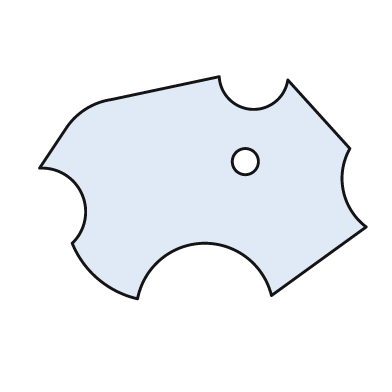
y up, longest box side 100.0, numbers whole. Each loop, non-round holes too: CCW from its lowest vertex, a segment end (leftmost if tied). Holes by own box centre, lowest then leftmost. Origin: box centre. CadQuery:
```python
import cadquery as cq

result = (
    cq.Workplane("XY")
    .moveTo(-20.0, -34.0)
    .threePointArc((0.0, -17.0), (21.0, -33.0))
    .lineTo(50.0, -12.0)
    .threePointArc((43.0, -1.0), (45.0, 12.0))
    .lineTo(26.0, 33.0)
    .threePointArc((15.0, 24.0), (5.0, 34.0))
    .lineTo(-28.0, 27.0)
    .threePointArc((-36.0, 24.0), (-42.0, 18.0))
    .lineTo(-50.0, 6.0)
    .threePointArc((-37.0, -2.0), (-40.0, -17.0))
    .threePointArc((-32.0, -28.0), (-20.0, -34.0))
    .close()
    .moveTo(13.0, 8.0)
    .circle(4.0)
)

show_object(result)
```